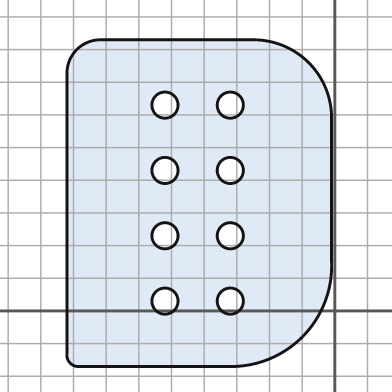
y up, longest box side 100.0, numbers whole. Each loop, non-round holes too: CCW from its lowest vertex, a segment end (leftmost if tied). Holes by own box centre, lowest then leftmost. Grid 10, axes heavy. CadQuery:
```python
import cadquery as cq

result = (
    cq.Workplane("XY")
    .moveTo(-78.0, -17.0)
    .lineTo(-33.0, -17.0)
    .threePointArc((-10.0, -8.0), (-1.0, 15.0))
    .lineTo(-1.0, 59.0)
    .threePointArc((-8.0, 76.0), (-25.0, 83.0))
    .lineTo(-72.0, 83.0)
    .threePointArc((-79.0, 80.0), (-82.0, 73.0))
    .lineTo(-82.0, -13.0)
    .threePointArc((-81.0, -16.0), (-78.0, -17.0))
    .close()
    .moveTo(-52.0, 3.0)
    .circle(4.0)
    .moveTo(-32.0, 3.0)
    .circle(4.0)
    .moveTo(-52.0, 23.0)
    .circle(4.0)
    .moveTo(-32.0, 23.0)
    .circle(4.0)
    .moveTo(-52.0, 43.0)
    .circle(4.0)
    .moveTo(-32.0, 43.0)
    .circle(4.0)
    .moveTo(-52.0, 63.0)
    .circle(4.0)
    .moveTo(-32.0, 63.0)
    .circle(4.0)
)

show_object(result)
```